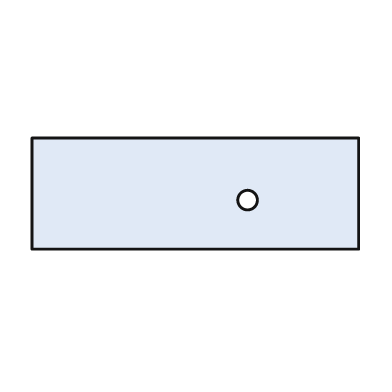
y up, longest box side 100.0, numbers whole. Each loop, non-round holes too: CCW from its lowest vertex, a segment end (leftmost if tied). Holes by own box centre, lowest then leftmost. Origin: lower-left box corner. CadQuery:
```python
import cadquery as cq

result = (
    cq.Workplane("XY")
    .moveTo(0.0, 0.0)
    .lineTo(100.0, 0.0)
    .lineTo(100.0, 34.0)
    .lineTo(0.0, 34.0)
    .close()
    .moveTo(66.0, 15.0)
    .circle(3.0)
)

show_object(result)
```